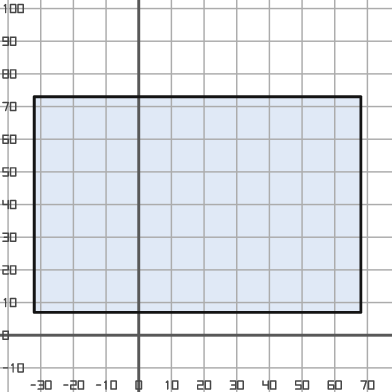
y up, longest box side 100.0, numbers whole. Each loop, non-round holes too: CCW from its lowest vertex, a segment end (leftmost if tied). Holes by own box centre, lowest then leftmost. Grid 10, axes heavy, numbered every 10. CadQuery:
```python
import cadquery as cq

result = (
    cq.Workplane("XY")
    .moveTo(-32.0, 7.0)
    .lineTo(68.0, 7.0)
    .lineTo(68.0, 73.0)
    .lineTo(-32.0, 73.0)
    .close()
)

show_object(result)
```